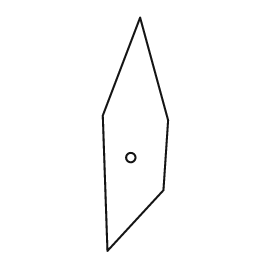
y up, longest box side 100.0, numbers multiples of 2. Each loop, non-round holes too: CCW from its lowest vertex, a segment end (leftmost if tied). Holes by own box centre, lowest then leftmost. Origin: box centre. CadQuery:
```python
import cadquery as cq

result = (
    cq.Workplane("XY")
    .moveTo(-12.0, -50.0)
    .lineTo(12.0, -24.0)
    .lineTo(14.0, 6.0)
    .lineTo(2.0, 50.0)
    .lineTo(-14.0, 8.0)
    .close()
    .moveTo(-2.0, -10.0)
    .circle(2.0)
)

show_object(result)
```